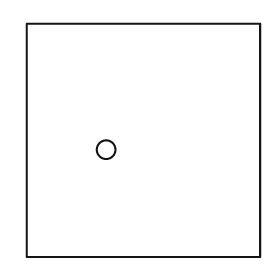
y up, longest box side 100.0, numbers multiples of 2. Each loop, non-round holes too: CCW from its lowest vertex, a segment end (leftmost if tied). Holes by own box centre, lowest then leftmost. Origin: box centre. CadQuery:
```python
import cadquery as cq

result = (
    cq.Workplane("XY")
    .moveTo(-50.0, -50.0)
    .lineTo(50.0, -50.0)
    .lineTo(50.0, 50.0)
    .lineTo(-50.0, 50.0)
    .close()
    .moveTo(-16.0, -4.0)
    .circle(4.0)
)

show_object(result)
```